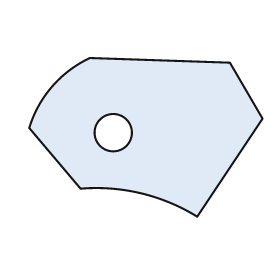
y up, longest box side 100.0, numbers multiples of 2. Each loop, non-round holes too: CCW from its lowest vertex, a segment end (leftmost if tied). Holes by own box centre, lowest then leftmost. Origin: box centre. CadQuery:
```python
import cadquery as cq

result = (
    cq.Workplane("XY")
    .moveTo(22.0, -34.0)
    .lineTo(50.0, 8.0)
    .lineTo(36.0, 32.0)
    .lineTo(-24.0, 34.0)
    .threePointArc((-40.0, 22.0), (-50.0, 4.0))
    .lineTo(-28.0, -22.0)
    .threePointArc((-2.0, -24.0), (22.0, -34.0))
    .close()
    .moveTo(-14.0, 2.0)
    .circle(8.0)
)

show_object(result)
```